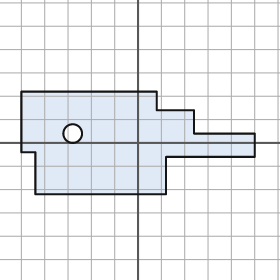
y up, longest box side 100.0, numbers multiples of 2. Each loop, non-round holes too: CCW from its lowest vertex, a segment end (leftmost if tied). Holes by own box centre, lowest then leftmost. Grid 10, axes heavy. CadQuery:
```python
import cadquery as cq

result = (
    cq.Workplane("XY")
    .moveTo(-44.0, -22.0)
    .lineTo(12.0, -22.0)
    .lineTo(12.0, -6.0)
    .lineTo(50.0, -6.0)
    .lineTo(50.0, 4.0)
    .lineTo(24.0, 4.0)
    .lineTo(24.0, 14.0)
    .lineTo(8.0, 14.0)
    .lineTo(8.0, 22.0)
    .lineTo(-50.0, 22.0)
    .lineTo(-50.0, -4.0)
    .lineTo(-44.0, -4.0)
    .close()
    .moveTo(-28.0, 4.0)
    .circle(4.0)
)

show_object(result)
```